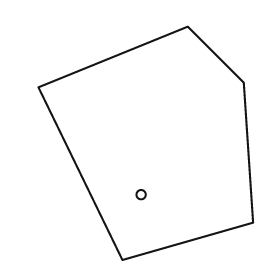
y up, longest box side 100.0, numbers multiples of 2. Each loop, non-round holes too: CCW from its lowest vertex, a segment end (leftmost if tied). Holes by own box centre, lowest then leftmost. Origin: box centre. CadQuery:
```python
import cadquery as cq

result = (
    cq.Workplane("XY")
    .moveTo(-10.0, -50.0)
    .lineTo(46.0, -34.0)
    .lineTo(42.0, 26.0)
    .lineTo(18.0, 50.0)
    .lineTo(-46.0, 24.0)
    .close()
    .moveTo(-2.0, -22.0)
    .circle(2.0)
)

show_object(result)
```